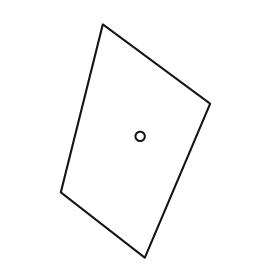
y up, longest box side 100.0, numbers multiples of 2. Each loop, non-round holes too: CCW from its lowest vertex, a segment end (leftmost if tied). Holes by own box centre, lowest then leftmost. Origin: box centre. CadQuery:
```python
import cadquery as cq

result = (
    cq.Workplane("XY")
    .moveTo(4.0, -50.0)
    .lineTo(32.0, 16.0)
    .lineTo(-14.0, 50.0)
    .lineTo(-32.0, -22.0)
    .close()
    .moveTo(2.0, 2.0)
    .circle(2.0)
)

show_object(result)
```